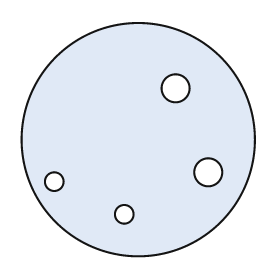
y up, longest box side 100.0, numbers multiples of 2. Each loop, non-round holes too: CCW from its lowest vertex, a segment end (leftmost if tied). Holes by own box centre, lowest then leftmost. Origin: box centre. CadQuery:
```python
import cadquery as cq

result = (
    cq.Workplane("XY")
    .moveTo(0.0, 0.0)
    .circle(50.0)
    .moveTo(-6.0, -32.0)
    .circle(4.0)
    .moveTo(-36.0, -18.0)
    .circle(4.0)
    .moveTo(30.0, -14.0)
    .circle(6.0)
    .moveTo(16.0, 22.0)
    .circle(6.0)
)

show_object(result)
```